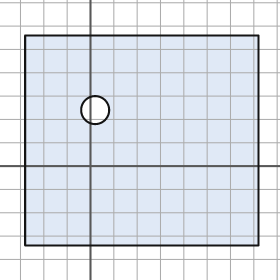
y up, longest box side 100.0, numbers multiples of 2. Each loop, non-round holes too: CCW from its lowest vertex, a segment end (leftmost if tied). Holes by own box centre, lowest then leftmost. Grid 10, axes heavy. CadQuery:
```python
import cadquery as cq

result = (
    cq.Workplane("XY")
    .moveTo(-28.0, -34.0)
    .lineTo(72.0, -34.0)
    .lineTo(72.0, 56.0)
    .lineTo(-28.0, 56.0)
    .close()
    .moveTo(2.0, 24.0)
    .circle(6.0)
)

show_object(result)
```